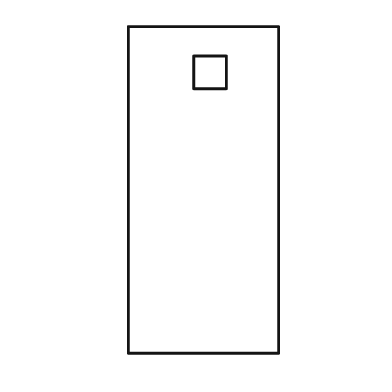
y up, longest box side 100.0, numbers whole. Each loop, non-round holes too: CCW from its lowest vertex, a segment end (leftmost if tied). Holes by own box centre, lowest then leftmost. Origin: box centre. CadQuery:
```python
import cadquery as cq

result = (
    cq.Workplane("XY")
    .moveTo(-23.0, -50.0)
    .lineTo(23.0, -50.0)
    .lineTo(23.0, 50.0)
    .lineTo(-23.0, 50.0)
    .close()
    .moveTo(-3.0, 31.0)
    .lineTo(7.0, 31.0)
    .lineTo(7.0, 41.0)
    .lineTo(-3.0, 41.0)
    .close()
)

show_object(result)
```